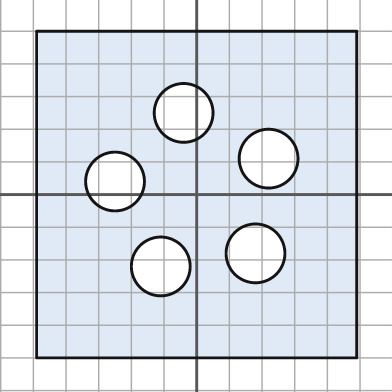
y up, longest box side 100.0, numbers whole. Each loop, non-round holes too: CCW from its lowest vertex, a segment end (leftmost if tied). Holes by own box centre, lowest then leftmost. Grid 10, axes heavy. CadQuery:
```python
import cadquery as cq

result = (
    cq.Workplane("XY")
    .moveTo(-49.0, -50.0)
    .lineTo(49.0, -50.0)
    .lineTo(49.0, 50.0)
    .lineTo(-49.0, 50.0)
    .close()
    .moveTo(-11.0, -22.0)
    .circle(9.0)
    .moveTo(18.0, -18.0)
    .circle(9.0)
    .moveTo(-25.0, 4.0)
    .circle(9.0)
    .moveTo(22.0, 11.0)
    .circle(9.0)
    .moveTo(-4.0, 25.0)
    .circle(9.0)
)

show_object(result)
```